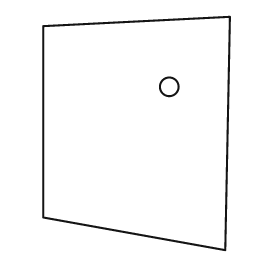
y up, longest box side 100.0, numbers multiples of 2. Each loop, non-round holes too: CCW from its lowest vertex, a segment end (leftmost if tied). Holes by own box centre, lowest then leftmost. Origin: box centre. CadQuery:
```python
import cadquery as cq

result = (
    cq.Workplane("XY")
    .moveTo(38.0, -50.0)
    .lineTo(40.0, 50.0)
    .lineTo(-40.0, 46.0)
    .lineTo(-40.0, -36.0)
    .close()
    .moveTo(14.0, 20.0)
    .circle(4.0)
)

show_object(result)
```